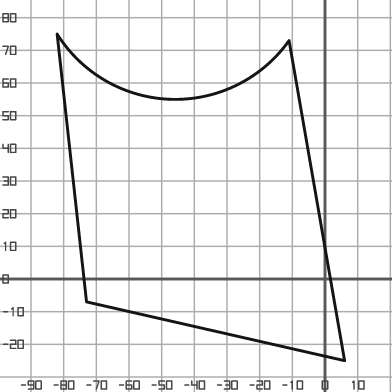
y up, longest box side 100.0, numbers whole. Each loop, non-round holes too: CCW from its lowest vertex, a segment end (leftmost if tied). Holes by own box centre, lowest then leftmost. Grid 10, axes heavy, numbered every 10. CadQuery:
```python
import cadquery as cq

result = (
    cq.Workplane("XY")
    .moveTo(6.0, -25.0)
    .lineTo(-11.0, 73.0)
    .threePointArc((-47.0, 55.0), (-82.0, 75.0))
    .lineTo(-73.0, -7.0)
    .close()
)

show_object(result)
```